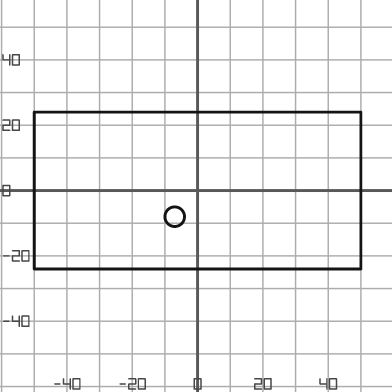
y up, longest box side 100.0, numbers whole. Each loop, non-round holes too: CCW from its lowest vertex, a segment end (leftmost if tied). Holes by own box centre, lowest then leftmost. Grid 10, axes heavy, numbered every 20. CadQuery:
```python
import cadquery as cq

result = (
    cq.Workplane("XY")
    .moveTo(-50.0, -24.0)
    .lineTo(50.0, -24.0)
    .lineTo(50.0, 24.0)
    .lineTo(-50.0, 24.0)
    .close()
    .moveTo(-7.0, -8.0)
    .circle(3.0)
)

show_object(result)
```